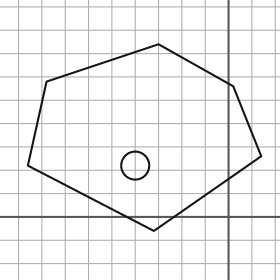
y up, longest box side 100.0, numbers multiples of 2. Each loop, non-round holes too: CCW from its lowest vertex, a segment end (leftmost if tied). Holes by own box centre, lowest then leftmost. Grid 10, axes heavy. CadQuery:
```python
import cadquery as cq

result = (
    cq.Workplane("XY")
    .moveTo(-32.0, -6.0)
    .lineTo(14.0, 26.0)
    .lineTo(2.0, 56.0)
    .lineTo(-30.0, 74.0)
    .lineTo(-78.0, 58.0)
    .lineTo(-86.0, 22.0)
    .close()
    .moveTo(-40.0, 22.0)
    .circle(6.0)
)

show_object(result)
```